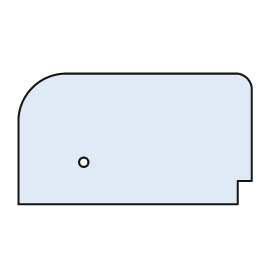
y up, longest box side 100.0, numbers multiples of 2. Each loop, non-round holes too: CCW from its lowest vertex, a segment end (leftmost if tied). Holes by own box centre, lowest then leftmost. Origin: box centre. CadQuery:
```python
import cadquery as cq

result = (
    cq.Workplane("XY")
    .moveTo(-50.0, -28.0)
    .lineTo(44.0, -28.0)
    .lineTo(44.0, -18.0)
    .lineTo(50.0, -18.0)
    .lineTo(50.0, 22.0)
    .threePointArc((48.0, 26.0), (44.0, 28.0))
    .lineTo(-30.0, 28.0)
    .threePointArc((-44.0, 22.0), (-50.0, 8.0))
    .close()
    .moveTo(-22.0, -10.0)
    .circle(2.0)
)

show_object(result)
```